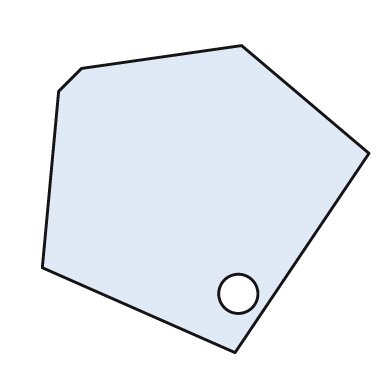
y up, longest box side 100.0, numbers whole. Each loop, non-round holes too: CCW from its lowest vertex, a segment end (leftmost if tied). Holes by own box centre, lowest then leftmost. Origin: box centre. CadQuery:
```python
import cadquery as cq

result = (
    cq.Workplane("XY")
    .moveTo(9.0, -47.0)
    .lineTo(50.0, 14.0)
    .lineTo(11.0, 47.0)
    .lineTo(-38.0, 40.0)
    .lineTo(-45.0, 33.0)
    .lineTo(-50.0, -21.0)
    .close()
    .moveTo(10.0, -29.0)
    .circle(6.0)
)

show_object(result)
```